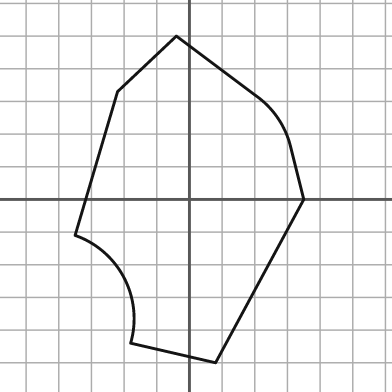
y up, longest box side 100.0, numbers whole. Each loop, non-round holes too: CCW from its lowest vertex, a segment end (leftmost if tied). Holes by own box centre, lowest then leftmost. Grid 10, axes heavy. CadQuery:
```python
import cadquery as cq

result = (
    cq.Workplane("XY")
    .moveTo(8.0, -50.0)
    .lineTo(35.0, 0.0)
    .lineTo(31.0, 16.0)
    .threePointArc((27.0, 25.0), (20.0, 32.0))
    .lineTo(-4.0, 50.0)
    .lineTo(-22.0, 33.0)
    .lineTo(-35.0, -11.0)
    .threePointArc((-20.0, -24.0), (-18.0, -44.0))
    .close()
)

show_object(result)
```